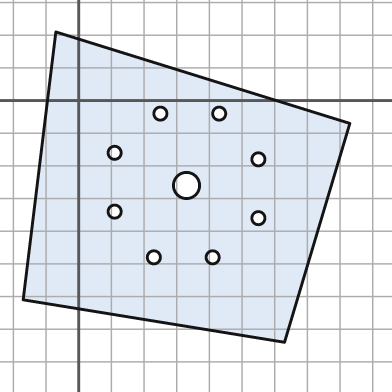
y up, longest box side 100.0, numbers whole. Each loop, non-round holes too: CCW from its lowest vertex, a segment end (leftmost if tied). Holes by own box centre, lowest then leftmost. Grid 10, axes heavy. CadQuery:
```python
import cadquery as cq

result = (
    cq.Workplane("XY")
    .moveTo(63.0, -74.0)
    .lineTo(83.0, -7.0)
    .lineTo(-7.0, 21.0)
    .lineTo(-17.0, -61.0)
    .close()
    .moveTo(23.0, -48.0)
    .circle(2.0)
    .moveTo(41.0, -48.0)
    .circle(2.0)
    .moveTo(55.0, -36.0)
    .circle(2.0)
    .moveTo(11.0, -34.0)
    .circle(2.0)
    .moveTo(33.0, -26.0)
    .circle(4.0)
    .moveTo(55.0, -18.0)
    .circle(2.0)
    .moveTo(11.0, -16.0)
    .circle(2.0)
    .moveTo(25.0, -4.0)
    .circle(2.0)
    .moveTo(43.0, -4.0)
    .circle(2.0)
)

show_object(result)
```